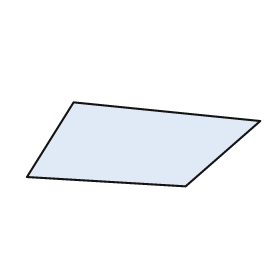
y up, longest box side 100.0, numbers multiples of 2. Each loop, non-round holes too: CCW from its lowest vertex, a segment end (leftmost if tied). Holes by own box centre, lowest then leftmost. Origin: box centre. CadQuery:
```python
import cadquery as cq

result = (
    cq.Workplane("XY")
    .moveTo(18.0, -18.0)
    .lineTo(50.0, 10.0)
    .lineTo(-30.0, 18.0)
    .lineTo(-50.0, -14.0)
    .close()
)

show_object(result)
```